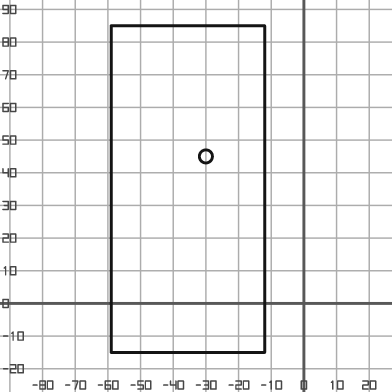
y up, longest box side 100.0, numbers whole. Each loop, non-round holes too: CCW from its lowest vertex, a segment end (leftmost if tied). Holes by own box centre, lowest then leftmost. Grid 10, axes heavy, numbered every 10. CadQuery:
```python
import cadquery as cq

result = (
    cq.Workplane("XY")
    .moveTo(-59.0, -15.0)
    .lineTo(-12.0, -15.0)
    .lineTo(-12.0, 85.0)
    .lineTo(-59.0, 85.0)
    .close()
    .moveTo(-30.0, 45.0)
    .circle(2.0)
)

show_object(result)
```